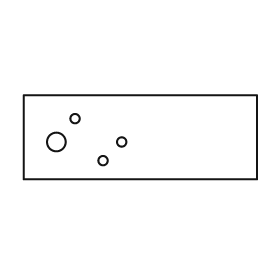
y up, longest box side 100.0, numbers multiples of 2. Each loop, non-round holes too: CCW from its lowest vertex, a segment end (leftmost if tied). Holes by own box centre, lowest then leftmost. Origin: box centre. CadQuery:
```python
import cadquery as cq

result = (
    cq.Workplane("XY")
    .moveTo(-50.0, -18.0)
    .lineTo(50.0, -18.0)
    .lineTo(50.0, 18.0)
    .lineTo(-50.0, 18.0)
    .close()
    .moveTo(-16.0, -10.0)
    .circle(2.0)
    .moveTo(-36.0, -2.0)
    .circle(4.0)
    .moveTo(-8.0, -2.0)
    .circle(2.0)
    .moveTo(-28.0, 8.0)
    .circle(2.0)
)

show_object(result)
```